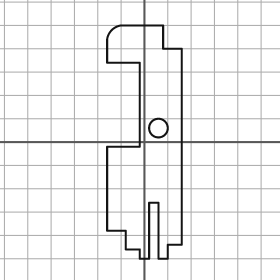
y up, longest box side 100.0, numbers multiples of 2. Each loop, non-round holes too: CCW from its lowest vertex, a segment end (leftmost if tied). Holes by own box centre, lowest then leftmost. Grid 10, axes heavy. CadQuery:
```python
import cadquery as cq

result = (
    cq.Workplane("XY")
    .moveTo(-2.0, -50.0)
    .lineTo(2.0, -50.0)
    .lineTo(2.0, -26.0)
    .lineTo(6.0, -26.0)
    .lineTo(6.0, -50.0)
    .lineTo(10.0, -50.0)
    .lineTo(10.0, -44.0)
    .lineTo(16.0, -44.0)
    .lineTo(16.0, 40.0)
    .lineTo(8.0, 40.0)
    .lineTo(8.0, 50.0)
    .lineTo(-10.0, 50.0)
    .threePointArc((-14.0, 48.0), (-16.0, 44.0))
    .lineTo(-16.0, 34.0)
    .lineTo(-2.0, 34.0)
    .lineTo(-2.0, -2.0)
    .lineTo(-16.0, -2.0)
    .lineTo(-16.0, -38.0)
    .lineTo(-8.0, -38.0)
    .lineTo(-8.0, -46.0)
    .lineTo(-2.0, -46.0)
    .close()
    .moveTo(6.0, 6.0)
    .circle(4.0)
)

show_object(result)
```